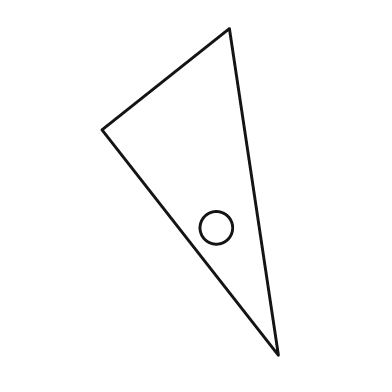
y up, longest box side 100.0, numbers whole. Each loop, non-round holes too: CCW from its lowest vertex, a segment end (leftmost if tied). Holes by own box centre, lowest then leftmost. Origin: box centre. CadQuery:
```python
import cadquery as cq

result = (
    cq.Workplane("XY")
    .moveTo(27.0, -50.0)
    .lineTo(12.0, 50.0)
    .lineTo(-27.0, 19.0)
    .close()
    .moveTo(8.0, -11.0)
    .circle(5.0)
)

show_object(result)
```